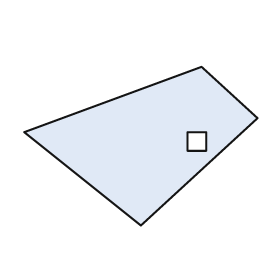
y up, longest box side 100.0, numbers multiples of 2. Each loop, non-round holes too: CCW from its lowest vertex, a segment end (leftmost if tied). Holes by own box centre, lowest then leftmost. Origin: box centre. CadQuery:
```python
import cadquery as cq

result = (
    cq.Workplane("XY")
    .moveTo(0.0, -34.0)
    .lineTo(50.0, 12.0)
    .lineTo(26.0, 34.0)
    .lineTo(-50.0, 6.0)
    .close()
    .moveTo(20.0, -2.0)
    .lineTo(28.0, -2.0)
    .lineTo(28.0, 6.0)
    .lineTo(20.0, 6.0)
    .close()
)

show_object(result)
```